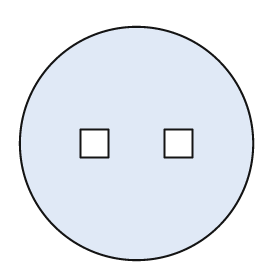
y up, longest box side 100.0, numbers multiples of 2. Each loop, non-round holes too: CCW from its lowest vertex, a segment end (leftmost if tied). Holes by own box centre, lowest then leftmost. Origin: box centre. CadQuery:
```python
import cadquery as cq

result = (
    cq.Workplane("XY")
    .moveTo(0.0, 0.0)
    .circle(50.0)
    .moveTo(-24.0, -6.0)
    .lineTo(-12.0, -6.0)
    .lineTo(-12.0, 6.0)
    .lineTo(-24.0, 6.0)
    .close()
    .moveTo(12.0, -6.0)
    .lineTo(24.0, -6.0)
    .lineTo(24.0, 6.0)
    .lineTo(12.0, 6.0)
    .close()
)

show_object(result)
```